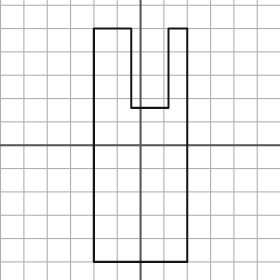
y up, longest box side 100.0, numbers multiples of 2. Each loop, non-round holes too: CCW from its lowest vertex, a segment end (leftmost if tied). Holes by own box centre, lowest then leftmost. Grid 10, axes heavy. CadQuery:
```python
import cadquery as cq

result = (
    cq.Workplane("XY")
    .moveTo(-20.0, -50.0)
    .lineTo(20.0, -50.0)
    .lineTo(20.0, 50.0)
    .lineTo(12.0, 50.0)
    .lineTo(12.0, 16.0)
    .lineTo(-4.0, 16.0)
    .lineTo(-4.0, 50.0)
    .lineTo(-20.0, 50.0)
    .close()
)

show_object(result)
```